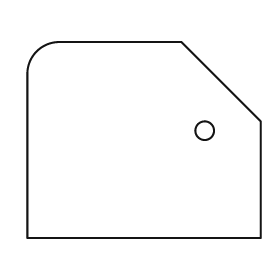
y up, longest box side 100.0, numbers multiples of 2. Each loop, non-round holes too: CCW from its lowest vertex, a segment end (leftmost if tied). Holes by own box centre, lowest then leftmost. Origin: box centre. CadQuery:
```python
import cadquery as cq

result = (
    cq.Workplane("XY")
    .moveTo(-50.0, -42.0)
    .lineTo(50.0, -42.0)
    .lineTo(50.0, 8.0)
    .lineTo(16.0, 42.0)
    .lineTo(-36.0, 42.0)
    .threePointArc((-46.0, 38.0), (-50.0, 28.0))
    .close()
    .moveTo(26.0, 4.0)
    .circle(4.0)
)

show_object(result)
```